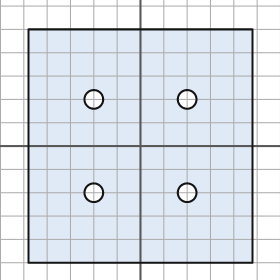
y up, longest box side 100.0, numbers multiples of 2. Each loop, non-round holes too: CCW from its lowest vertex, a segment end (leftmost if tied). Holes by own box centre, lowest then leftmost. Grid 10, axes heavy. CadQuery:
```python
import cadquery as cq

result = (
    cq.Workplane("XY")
    .moveTo(-48.0, -50.0)
    .lineTo(48.0, -50.0)
    .lineTo(48.0, 50.0)
    .lineTo(-48.0, 50.0)
    .close()
    .moveTo(-20.0, -20.0)
    .circle(4.0)
    .moveTo(20.0, -20.0)
    .circle(4.0)
    .moveTo(-20.0, 20.0)
    .circle(4.0)
    .moveTo(20.0, 20.0)
    .circle(4.0)
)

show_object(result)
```